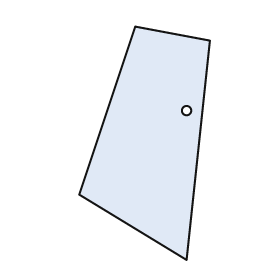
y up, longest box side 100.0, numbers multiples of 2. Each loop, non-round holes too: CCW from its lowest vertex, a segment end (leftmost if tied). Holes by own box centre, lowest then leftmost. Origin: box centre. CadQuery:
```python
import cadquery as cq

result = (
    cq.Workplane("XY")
    .moveTo(18.0, -50.0)
    .lineTo(28.0, 44.0)
    .lineTo(-4.0, 50.0)
    .lineTo(-28.0, -22.0)
    .close()
    .moveTo(18.0, 14.0)
    .circle(2.0)
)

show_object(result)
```